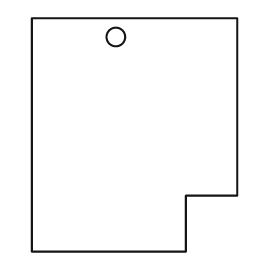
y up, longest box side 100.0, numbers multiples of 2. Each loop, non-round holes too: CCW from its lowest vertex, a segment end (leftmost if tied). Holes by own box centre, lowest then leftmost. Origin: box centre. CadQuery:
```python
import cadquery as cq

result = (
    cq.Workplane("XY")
    .moveTo(-44.0, -50.0)
    .lineTo(22.0, -50.0)
    .lineTo(22.0, -26.0)
    .lineTo(44.0, -26.0)
    .lineTo(44.0, 50.0)
    .lineTo(-44.0, 50.0)
    .close()
    .moveTo(-8.0, 42.0)
    .circle(4.0)
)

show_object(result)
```